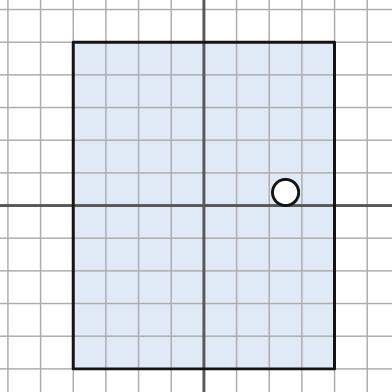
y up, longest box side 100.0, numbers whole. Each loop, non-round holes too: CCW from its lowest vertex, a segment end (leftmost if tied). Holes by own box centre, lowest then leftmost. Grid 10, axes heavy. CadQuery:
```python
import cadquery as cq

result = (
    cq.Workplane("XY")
    .moveTo(-40.0, -50.0)
    .lineTo(40.0, -50.0)
    .lineTo(40.0, 50.0)
    .lineTo(-40.0, 50.0)
    .close()
    .moveTo(25.0, 4.0)
    .circle(4.0)
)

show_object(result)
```